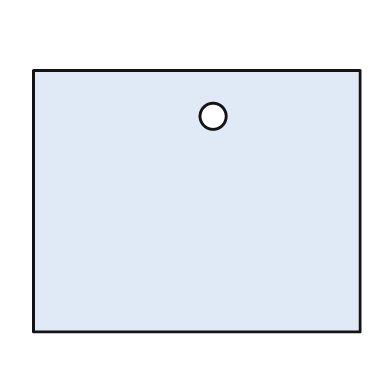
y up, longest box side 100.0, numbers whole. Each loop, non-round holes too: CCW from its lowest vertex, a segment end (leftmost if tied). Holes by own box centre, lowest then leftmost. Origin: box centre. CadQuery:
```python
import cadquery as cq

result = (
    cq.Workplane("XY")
    .moveTo(-50.0, -40.0)
    .lineTo(50.0, -40.0)
    .lineTo(50.0, 40.0)
    .lineTo(-50.0, 40.0)
    .close()
    .moveTo(5.0, 26.0)
    .circle(4.0)
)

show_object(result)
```